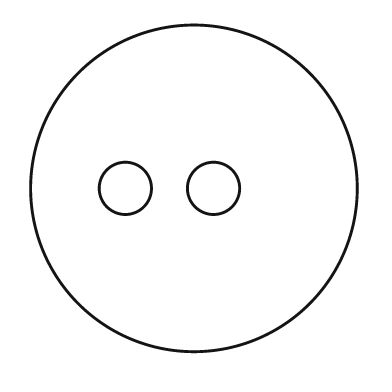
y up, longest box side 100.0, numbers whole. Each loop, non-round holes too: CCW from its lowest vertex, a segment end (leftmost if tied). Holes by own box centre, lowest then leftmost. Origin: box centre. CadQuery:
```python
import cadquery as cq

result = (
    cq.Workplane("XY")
    .moveTo(0.0, 0.0)
    .circle(50.0)
    .moveTo(-21.0, 0.0)
    .circle(8.0)
    .moveTo(6.0, 0.0)
    .circle(8.0)
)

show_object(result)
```